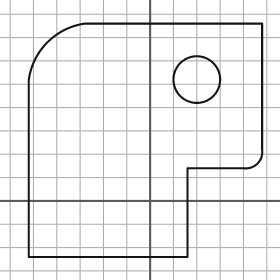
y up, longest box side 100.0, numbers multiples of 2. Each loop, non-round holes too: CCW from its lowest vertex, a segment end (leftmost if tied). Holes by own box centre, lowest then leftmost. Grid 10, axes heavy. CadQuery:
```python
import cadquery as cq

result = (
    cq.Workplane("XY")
    .moveTo(-52.0, -24.0)
    .lineTo(16.0, -24.0)
    .lineTo(16.0, 14.0)
    .lineTo(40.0, 14.0)
    .threePointArc((46.0, 16.0), (48.0, 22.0))
    .lineTo(48.0, 76.0)
    .lineTo(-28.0, 76.0)
    .threePointArc((-44.0, 68.0), (-52.0, 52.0))
    .close()
    .moveTo(20.0, 52.0)
    .circle(10.0)
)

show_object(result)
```